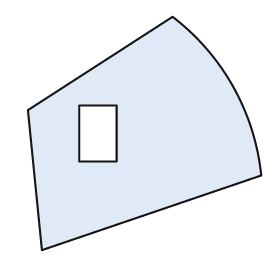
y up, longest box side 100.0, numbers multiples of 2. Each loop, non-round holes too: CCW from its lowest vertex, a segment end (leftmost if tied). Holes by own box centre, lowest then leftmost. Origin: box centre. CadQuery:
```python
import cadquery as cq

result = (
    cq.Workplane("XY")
    .moveTo(-44.0, -50.0)
    .lineTo(50.0, -18.0)
    .threePointArc((38.0, 20.0), (12.0, 50.0))
    .lineTo(-50.0, 10.0)
    .close()
    .moveTo(-28.0, -12.0)
    .lineTo(-12.0, -12.0)
    .lineTo(-12.0, 12.0)
    .lineTo(-28.0, 12.0)
    .close()
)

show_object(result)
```